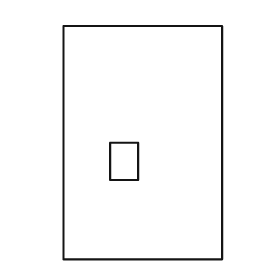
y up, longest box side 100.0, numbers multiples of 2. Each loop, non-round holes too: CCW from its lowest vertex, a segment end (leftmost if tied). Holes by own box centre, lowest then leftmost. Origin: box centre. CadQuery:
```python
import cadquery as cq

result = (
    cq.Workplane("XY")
    .moveTo(-34.0, -50.0)
    .lineTo(34.0, -50.0)
    .lineTo(34.0, 50.0)
    .lineTo(-34.0, 50.0)
    .close()
    .moveTo(-14.0, -16.0)
    .lineTo(-2.0, -16.0)
    .lineTo(-2.0, 0.0)
    .lineTo(-14.0, 0.0)
    .close()
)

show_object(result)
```